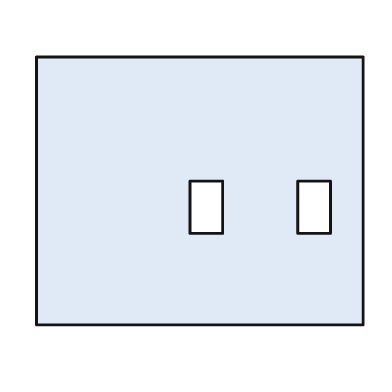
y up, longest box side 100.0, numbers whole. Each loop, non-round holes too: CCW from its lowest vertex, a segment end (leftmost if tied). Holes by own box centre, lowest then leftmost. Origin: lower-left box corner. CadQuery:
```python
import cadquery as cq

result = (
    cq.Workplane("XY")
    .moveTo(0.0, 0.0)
    .lineTo(100.0, 0.0)
    .lineTo(100.0, 82.0)
    .lineTo(0.0, 82.0)
    .close()
    .moveTo(47.0, 28.0)
    .lineTo(57.0, 28.0)
    .lineTo(57.0, 44.0)
    .lineTo(47.0, 44.0)
    .close()
    .moveTo(80.0, 28.0)
    .lineTo(90.0, 28.0)
    .lineTo(90.0, 44.0)
    .lineTo(80.0, 44.0)
    .close()
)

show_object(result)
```